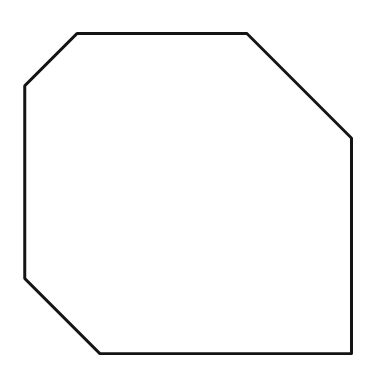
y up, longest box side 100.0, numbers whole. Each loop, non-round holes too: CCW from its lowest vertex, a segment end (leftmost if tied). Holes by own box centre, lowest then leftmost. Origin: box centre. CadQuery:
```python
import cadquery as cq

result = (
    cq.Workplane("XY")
    .moveTo(-27.0, -49.0)
    .lineTo(50.0, -49.0)
    .lineTo(50.0, 17.0)
    .lineTo(18.0, 49.0)
    .lineTo(-34.0, 49.0)
    .lineTo(-50.0, 33.0)
    .lineTo(-50.0, -26.0)
    .close()
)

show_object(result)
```